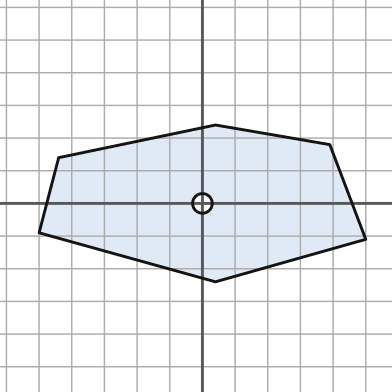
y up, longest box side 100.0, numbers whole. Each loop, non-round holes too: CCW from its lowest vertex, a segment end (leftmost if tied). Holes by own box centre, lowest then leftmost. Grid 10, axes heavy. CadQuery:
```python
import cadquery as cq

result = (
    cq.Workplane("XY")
    .moveTo(4.0, -24.0)
    .lineTo(50.0, -11.0)
    .lineTo(39.0, 18.0)
    .lineTo(4.0, 24.0)
    .lineTo(-44.0, 14.0)
    .lineTo(-50.0, -9.0)
    .close()
    .moveTo(0.0, 0.0)
    .circle(3.0)
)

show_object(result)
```